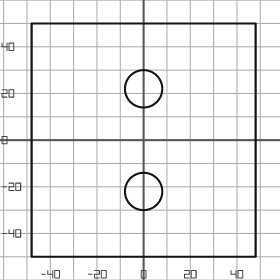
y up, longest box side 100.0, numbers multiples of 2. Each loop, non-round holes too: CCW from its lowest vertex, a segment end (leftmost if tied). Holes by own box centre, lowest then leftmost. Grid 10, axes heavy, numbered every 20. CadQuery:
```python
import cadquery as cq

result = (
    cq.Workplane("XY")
    .moveTo(-48.0, -50.0)
    .lineTo(48.0, -50.0)
    .lineTo(48.0, 50.0)
    .lineTo(-48.0, 50.0)
    .close()
    .moveTo(0.0, -22.0)
    .circle(8.0)
    .moveTo(0.0, 22.0)
    .circle(8.0)
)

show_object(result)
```